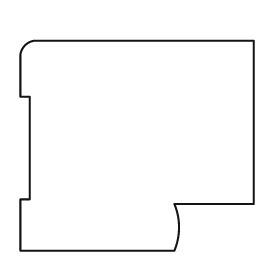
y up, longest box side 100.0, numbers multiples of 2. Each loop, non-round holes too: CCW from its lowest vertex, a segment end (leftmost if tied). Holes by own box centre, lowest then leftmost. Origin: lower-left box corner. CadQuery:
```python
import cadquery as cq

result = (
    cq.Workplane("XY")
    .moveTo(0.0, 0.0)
    .lineTo(66.0, 0.0)
    .threePointArc((68.0, 10.0), (66.0, 20.0))
    .lineTo(100.0, 20.0)
    .lineTo(100.0, 90.0)
    .lineTo(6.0, 90.0)
    .threePointArc((2.0, 88.0), (0.0, 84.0))
    .lineTo(0.0, 66.0)
    .lineTo(4.0, 66.0)
    .lineTo(4.0, 22.0)
    .lineTo(0.0, 22.0)
    .close()
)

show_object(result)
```